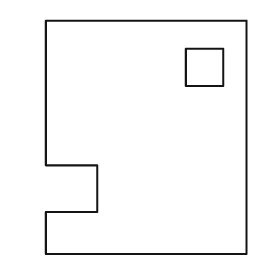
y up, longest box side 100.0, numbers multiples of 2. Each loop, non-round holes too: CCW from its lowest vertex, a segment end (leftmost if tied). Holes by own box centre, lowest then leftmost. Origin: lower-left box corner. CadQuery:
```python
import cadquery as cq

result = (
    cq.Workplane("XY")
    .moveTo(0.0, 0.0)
    .lineTo(86.0, 0.0)
    .lineTo(86.0, 100.0)
    .lineTo(0.0, 100.0)
    .lineTo(0.0, 38.0)
    .lineTo(22.0, 38.0)
    .lineTo(22.0, 18.0)
    .lineTo(0.0, 18.0)
    .close()
    .moveTo(60.0, 72.0)
    .lineTo(76.0, 72.0)
    .lineTo(76.0, 88.0)
    .lineTo(60.0, 88.0)
    .close()
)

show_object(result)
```